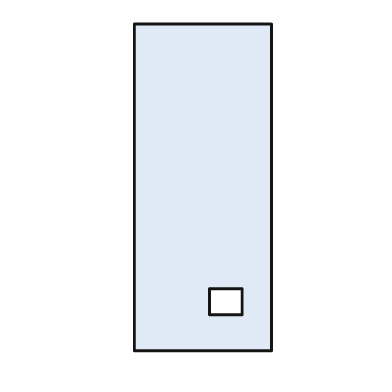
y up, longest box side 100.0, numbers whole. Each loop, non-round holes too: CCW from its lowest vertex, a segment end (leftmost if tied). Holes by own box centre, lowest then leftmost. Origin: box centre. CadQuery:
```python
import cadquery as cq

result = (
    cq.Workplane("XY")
    .moveTo(-21.0, -50.0)
    .lineTo(21.0, -50.0)
    .lineTo(21.0, 50.0)
    .lineTo(-21.0, 50.0)
    .close()
    .moveTo(2.0, -39.0)
    .lineTo(12.0, -39.0)
    .lineTo(12.0, -31.0)
    .lineTo(2.0, -31.0)
    .close()
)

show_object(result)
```